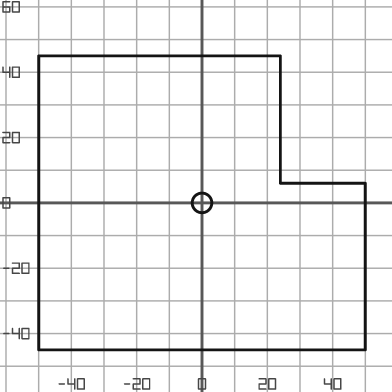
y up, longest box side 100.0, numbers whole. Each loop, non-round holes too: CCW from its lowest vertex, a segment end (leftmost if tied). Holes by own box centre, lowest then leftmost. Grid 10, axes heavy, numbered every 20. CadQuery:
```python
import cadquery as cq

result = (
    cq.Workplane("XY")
    .moveTo(-50.0, -45.0)
    .lineTo(50.0, -45.0)
    .lineTo(50.0, 6.0)
    .lineTo(24.0, 6.0)
    .lineTo(24.0, 45.0)
    .lineTo(-50.0, 45.0)
    .close()
    .moveTo(0.0, 0.0)
    .circle(3.0)
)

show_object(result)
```